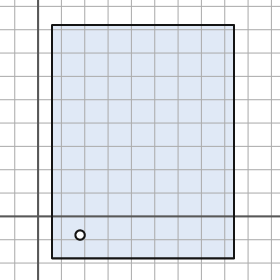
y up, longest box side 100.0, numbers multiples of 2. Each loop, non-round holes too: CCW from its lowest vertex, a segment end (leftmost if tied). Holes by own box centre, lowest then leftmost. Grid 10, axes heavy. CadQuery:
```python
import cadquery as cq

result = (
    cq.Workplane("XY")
    .moveTo(6.0, -18.0)
    .lineTo(84.0, -18.0)
    .lineTo(84.0, 82.0)
    .lineTo(6.0, 82.0)
    .close()
    .moveTo(18.0, -8.0)
    .circle(2.0)
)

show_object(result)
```